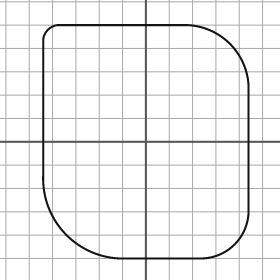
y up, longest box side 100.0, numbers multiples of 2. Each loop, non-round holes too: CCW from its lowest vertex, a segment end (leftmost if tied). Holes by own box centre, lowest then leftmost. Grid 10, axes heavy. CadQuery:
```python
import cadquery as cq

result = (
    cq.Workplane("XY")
    .moveTo(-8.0, -50.0)
    .lineTo(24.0, -50.0)
    .threePointArc((38.0, -44.0), (44.0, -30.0))
    .lineTo(44.0, 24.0)
    .threePointArc((36.0, 42.0), (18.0, 50.0))
    .lineTo(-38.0, 50.0)
    .threePointArc((-42.0, 48.0), (-44.0, 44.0))
    .lineTo(-44.0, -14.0)
    .threePointArc((-34.0, -40.0), (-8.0, -50.0))
    .close()
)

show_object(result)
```